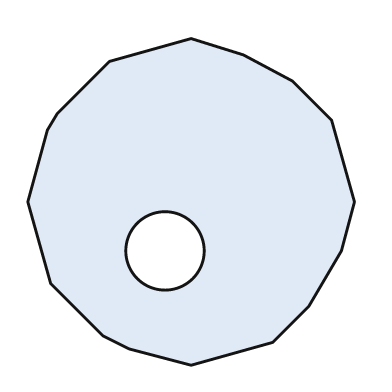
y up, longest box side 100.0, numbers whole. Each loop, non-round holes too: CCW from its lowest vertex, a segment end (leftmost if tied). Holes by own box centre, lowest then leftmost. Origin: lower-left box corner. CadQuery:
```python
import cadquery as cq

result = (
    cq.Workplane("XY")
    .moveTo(50.0, 0.0)
    .lineTo(75.0, 7.0)
    .lineTo(86.0, 18.0)
    .lineTo(96.0, 35.0)
    .lineTo(100.0, 50.0)
    .lineTo(93.0, 75.0)
    .lineTo(81.0, 87.0)
    .lineTo(66.0, 95.0)
    .lineTo(50.0, 100.0)
    .lineTo(25.0, 93.0)
    .lineTo(9.0, 77.0)
    .lineTo(6.0, 72.0)
    .lineTo(0.0, 50.0)
    .lineTo(7.0, 25.0)
    .lineTo(23.0, 9.0)
    .lineTo(31.0, 5.0)
    .close()
    .moveTo(42.0, 35.0)
    .circle(12.0)
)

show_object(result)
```